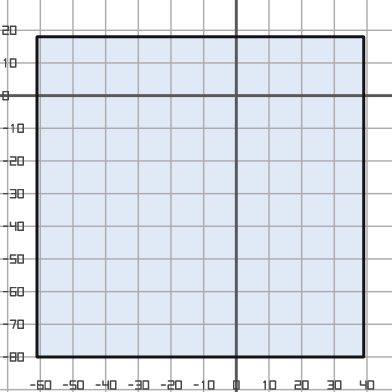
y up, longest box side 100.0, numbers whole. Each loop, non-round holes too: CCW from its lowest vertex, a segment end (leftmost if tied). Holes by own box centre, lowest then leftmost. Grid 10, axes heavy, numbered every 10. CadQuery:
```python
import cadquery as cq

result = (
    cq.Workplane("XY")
    .moveTo(-61.0, -80.0)
    .lineTo(39.0, -80.0)
    .lineTo(39.0, 18.0)
    .lineTo(-61.0, 18.0)
    .close()
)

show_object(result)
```